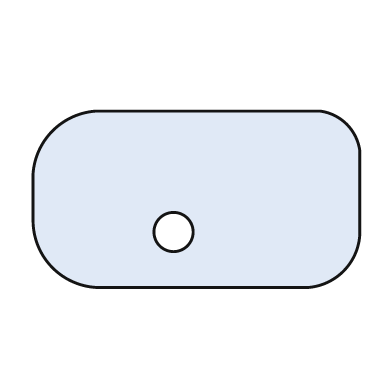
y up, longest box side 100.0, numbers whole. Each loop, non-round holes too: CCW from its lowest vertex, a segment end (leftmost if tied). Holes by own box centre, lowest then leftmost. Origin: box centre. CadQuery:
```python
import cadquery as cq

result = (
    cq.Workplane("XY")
    .moveTo(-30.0, -27.0)
    .lineTo(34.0, -27.0)
    .threePointArc((45.0, -22.0), (50.0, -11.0))
    .lineTo(50.0, 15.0)
    .threePointArc((46.0, 23.0), (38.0, 27.0))
    .lineTo(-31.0, 27.0)
    .threePointArc((-44.0, 21.0), (-50.0, 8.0))
    .lineTo(-50.0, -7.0)
    .threePointArc((-44.0, -21.0), (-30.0, -27.0))
    .close()
    .moveTo(-7.0, -10.0)
    .circle(6.0)
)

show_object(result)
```